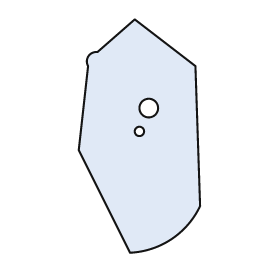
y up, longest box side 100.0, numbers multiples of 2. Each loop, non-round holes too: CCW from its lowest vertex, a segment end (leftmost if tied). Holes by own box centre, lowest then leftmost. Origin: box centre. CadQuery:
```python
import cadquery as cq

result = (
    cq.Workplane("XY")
    .moveTo(-4.0, -50.0)
    .threePointArc((14.0, -44.0), (26.0, -30.0))
    .lineTo(24.0, 30.0)
    .lineTo(-2.0, 50.0)
    .lineTo(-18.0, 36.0)
    .threePointArc((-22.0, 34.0), (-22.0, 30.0))
    .lineTo(-26.0, -6.0)
    .close()
    .moveTo(0.0, 2.0)
    .circle(2.0)
    .moveTo(4.0, 12.0)
    .circle(4.0)
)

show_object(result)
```